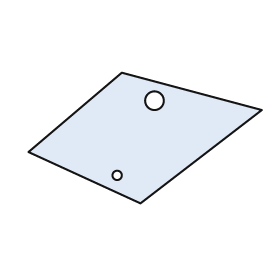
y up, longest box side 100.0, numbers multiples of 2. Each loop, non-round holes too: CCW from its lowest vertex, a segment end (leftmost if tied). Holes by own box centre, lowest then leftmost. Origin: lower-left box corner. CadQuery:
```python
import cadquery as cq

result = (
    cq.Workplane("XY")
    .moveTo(48.0, 0.0)
    .lineTo(100.0, 40.0)
    .lineTo(40.0, 56.0)
    .lineTo(0.0, 22.0)
    .close()
    .moveTo(38.0, 12.0)
    .circle(2.0)
    .moveTo(54.0, 44.0)
    .circle(4.0)
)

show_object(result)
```